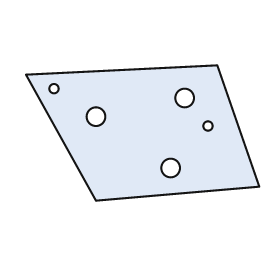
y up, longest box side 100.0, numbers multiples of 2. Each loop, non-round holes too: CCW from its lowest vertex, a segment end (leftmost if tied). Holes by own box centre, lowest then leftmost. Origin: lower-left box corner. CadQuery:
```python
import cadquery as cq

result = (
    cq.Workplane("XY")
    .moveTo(30.0, 0.0)
    .lineTo(100.0, 6.0)
    .lineTo(82.0, 58.0)
    .lineTo(0.0, 54.0)
    .close()
    .moveTo(62.0, 14.0)
    .circle(4.0)
    .moveTo(78.0, 32.0)
    .circle(2.0)
    .moveTo(30.0, 36.0)
    .circle(4.0)
    .moveTo(68.0, 44.0)
    .circle(4.0)
    .moveTo(12.0, 48.0)
    .circle(2.0)
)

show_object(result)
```